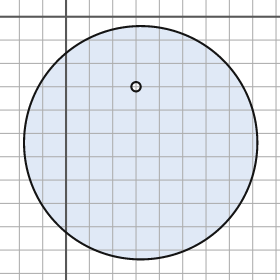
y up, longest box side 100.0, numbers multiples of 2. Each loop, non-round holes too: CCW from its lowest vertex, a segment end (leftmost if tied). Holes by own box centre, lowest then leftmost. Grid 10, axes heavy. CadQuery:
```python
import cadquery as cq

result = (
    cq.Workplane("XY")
    .moveTo(32.0, -54.0)
    .circle(50.0)
    .moveTo(30.0, -30.0)
    .circle(2.0)
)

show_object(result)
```